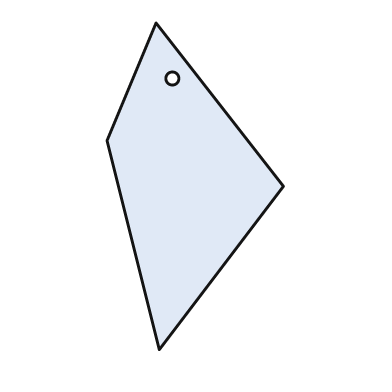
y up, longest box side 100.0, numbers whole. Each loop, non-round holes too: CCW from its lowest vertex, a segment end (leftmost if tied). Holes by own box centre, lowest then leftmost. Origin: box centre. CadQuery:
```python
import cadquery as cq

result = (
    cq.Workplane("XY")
    .moveTo(-11.0, -50.0)
    .lineTo(27.0, 0.0)
    .lineTo(-12.0, 50.0)
    .lineTo(-27.0, 14.0)
    .close()
    .moveTo(-7.0, 33.0)
    .circle(2.0)
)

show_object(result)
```